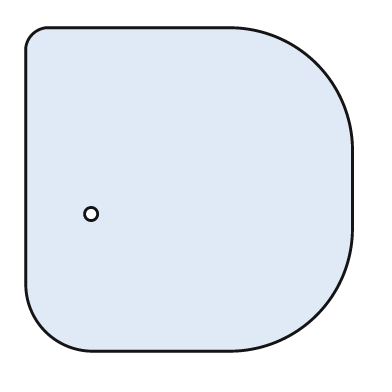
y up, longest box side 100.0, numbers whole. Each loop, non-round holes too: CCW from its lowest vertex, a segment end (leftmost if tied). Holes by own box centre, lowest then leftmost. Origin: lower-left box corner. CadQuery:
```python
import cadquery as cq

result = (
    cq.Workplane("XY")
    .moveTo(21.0, 0.0)
    .lineTo(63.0, 0.0)
    .threePointArc((89.0, 11.0), (100.0, 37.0))
    .lineTo(100.0, 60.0)
    .threePointArc((89.0, 88.0), (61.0, 99.0))
    .lineTo(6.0, 99.0)
    .threePointArc((2.0, 97.0), (0.0, 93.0))
    .lineTo(0.0, 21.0)
    .threePointArc((6.0, 6.0), (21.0, 0.0))
    .close()
    .moveTo(20.0, 42.0)
    .circle(2.0)
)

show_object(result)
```